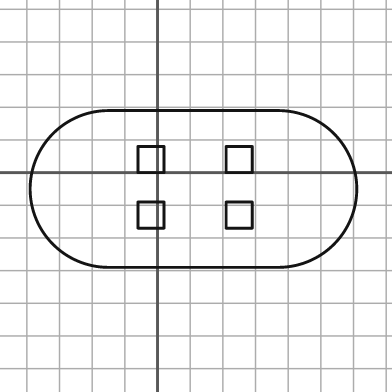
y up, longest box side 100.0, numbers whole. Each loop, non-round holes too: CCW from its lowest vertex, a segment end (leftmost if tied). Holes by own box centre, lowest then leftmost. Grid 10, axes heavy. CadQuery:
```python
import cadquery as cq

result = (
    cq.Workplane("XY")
    .moveTo(-15.0, -29.0)
    .lineTo(37.0, -29.0)
    .threePointArc((61.0, -5.0), (37.0, 19.0))
    .lineTo(-15.0, 19.0)
    .threePointArc((-39.0, -5.0), (-15.0, -29.0))
    .close()
    .moveTo(-6.0, -17.0)
    .lineTo(2.0, -17.0)
    .lineTo(2.0, -9.0)
    .lineTo(-6.0, -9.0)
    .close()
    .moveTo(21.0, -17.0)
    .lineTo(29.0, -17.0)
    .lineTo(29.0, -9.0)
    .lineTo(21.0, -9.0)
    .close()
    .moveTo(-6.0, 0.0)
    .lineTo(2.0, 0.0)
    .lineTo(2.0, 8.0)
    .lineTo(-6.0, 8.0)
    .close()
    .moveTo(21.0, 0.0)
    .lineTo(29.0, 0.0)
    .lineTo(29.0, 8.0)
    .lineTo(21.0, 8.0)
    .close()
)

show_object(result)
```